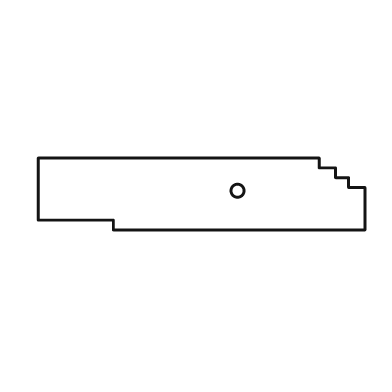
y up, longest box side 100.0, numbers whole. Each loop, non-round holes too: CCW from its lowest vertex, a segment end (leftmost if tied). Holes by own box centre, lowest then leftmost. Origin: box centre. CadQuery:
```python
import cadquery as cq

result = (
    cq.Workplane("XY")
    .moveTo(-27.0, -11.0)
    .lineTo(50.0, -11.0)
    .lineTo(50.0, 2.0)
    .lineTo(45.0, 2.0)
    .lineTo(45.0, 5.0)
    .lineTo(41.0, 5.0)
    .lineTo(41.0, 8.0)
    .lineTo(36.0, 8.0)
    .lineTo(36.0, 11.0)
    .lineTo(-50.0, 11.0)
    .lineTo(-50.0, -8.0)
    .lineTo(-27.0, -8.0)
    .close()
    .moveTo(11.0, 1.0)
    .circle(2.0)
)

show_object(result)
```